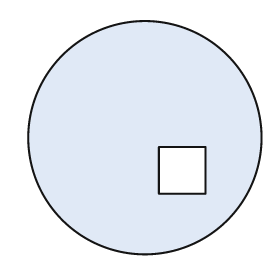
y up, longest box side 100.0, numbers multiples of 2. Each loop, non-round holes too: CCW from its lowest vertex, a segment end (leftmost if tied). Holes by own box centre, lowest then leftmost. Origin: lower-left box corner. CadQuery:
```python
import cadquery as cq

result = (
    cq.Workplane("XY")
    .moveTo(50.0, 50.0)
    .circle(50.0)
    .moveTo(56.0, 26.0)
    .lineTo(76.0, 26.0)
    .lineTo(76.0, 46.0)
    .lineTo(56.0, 46.0)
    .close()
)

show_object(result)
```